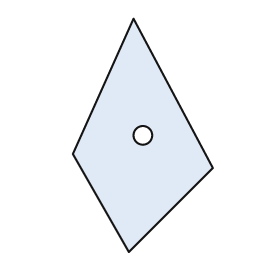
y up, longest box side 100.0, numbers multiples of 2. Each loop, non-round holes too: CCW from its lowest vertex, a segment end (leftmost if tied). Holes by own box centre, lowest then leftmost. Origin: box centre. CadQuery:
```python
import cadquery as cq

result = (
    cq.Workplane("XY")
    .moveTo(-6.0, -50.0)
    .lineTo(30.0, -14.0)
    .lineTo(-4.0, 50.0)
    .lineTo(-30.0, -8.0)
    .close()
    .moveTo(0.0, 0.0)
    .circle(4.0)
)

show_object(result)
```